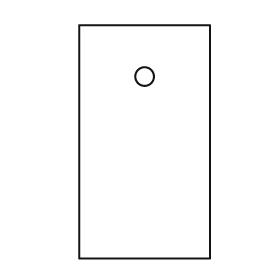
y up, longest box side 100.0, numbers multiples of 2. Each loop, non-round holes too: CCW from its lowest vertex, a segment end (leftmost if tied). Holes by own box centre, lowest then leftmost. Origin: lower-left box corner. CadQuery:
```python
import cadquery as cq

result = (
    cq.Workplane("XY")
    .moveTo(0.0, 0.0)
    .lineTo(56.0, 0.0)
    .lineTo(56.0, 100.0)
    .lineTo(0.0, 100.0)
    .close()
    .moveTo(28.0, 78.0)
    .circle(4.0)
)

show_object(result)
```